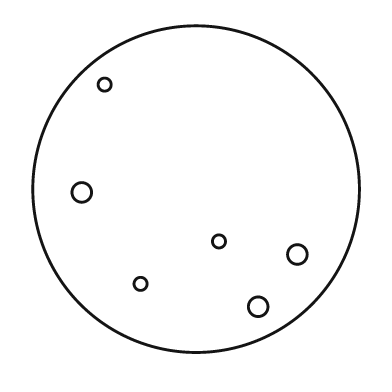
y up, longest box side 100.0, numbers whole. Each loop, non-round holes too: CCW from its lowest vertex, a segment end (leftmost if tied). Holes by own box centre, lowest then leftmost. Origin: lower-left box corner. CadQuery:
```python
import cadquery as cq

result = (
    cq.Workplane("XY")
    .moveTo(50.0, 50.0)
    .circle(50.0)
    .moveTo(69.0, 14.0)
    .circle(3.0)
    .moveTo(33.0, 21.0)
    .circle(2.0)
    .moveTo(81.0, 30.0)
    .circle(3.0)
    .moveTo(57.0, 34.0)
    .circle(2.0)
    .moveTo(15.0, 49.0)
    .circle(3.0)
    .moveTo(22.0, 82.0)
    .circle(2.0)
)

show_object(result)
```